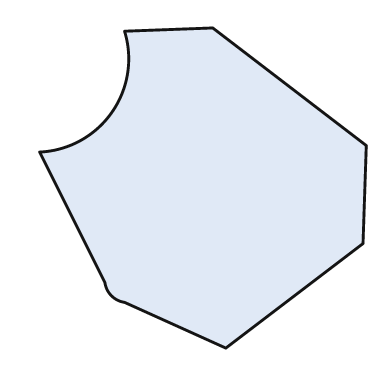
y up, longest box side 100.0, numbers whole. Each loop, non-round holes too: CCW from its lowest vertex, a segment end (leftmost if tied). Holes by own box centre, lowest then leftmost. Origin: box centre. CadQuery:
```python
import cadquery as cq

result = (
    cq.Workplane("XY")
    .moveTo(7.0, -49.0)
    .lineTo(49.0, -17.0)
    .lineTo(50.0, 13.0)
    .lineTo(3.0, 49.0)
    .lineTo(-24.0, 48.0)
    .threePointArc((-28.0, 23.0), (-50.0, 11.0))
    .lineTo(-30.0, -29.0)
    .threePointArc((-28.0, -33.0), (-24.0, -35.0))
    .close()
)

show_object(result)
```